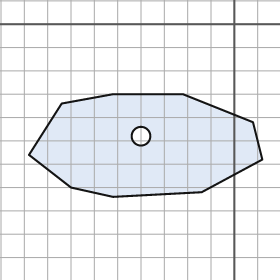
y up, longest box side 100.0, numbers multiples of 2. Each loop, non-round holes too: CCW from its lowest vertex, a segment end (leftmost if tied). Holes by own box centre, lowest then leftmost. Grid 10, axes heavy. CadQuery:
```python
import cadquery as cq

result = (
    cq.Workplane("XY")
    .moveTo(-52.0, -74.0)
    .lineTo(-14.0, -72.0)
    .lineTo(12.0, -58.0)
    .lineTo(8.0, -42.0)
    .lineTo(-22.0, -30.0)
    .lineTo(-52.0, -30.0)
    .lineTo(-74.0, -34.0)
    .lineTo(-88.0, -56.0)
    .lineTo(-70.0, -70.0)
    .close()
    .moveTo(-40.0, -48.0)
    .circle(4.0)
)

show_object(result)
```